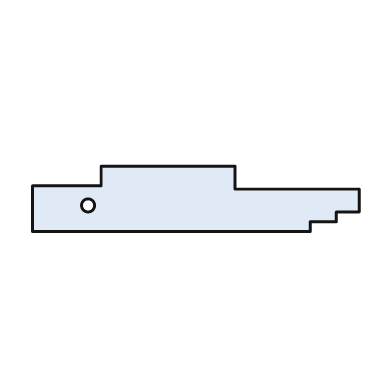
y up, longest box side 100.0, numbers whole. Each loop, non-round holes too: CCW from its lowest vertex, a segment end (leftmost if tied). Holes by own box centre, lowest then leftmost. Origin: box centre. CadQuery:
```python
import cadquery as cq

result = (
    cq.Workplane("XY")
    .moveTo(-50.0, -10.0)
    .lineTo(35.0, -10.0)
    .lineTo(35.0, -7.0)
    .lineTo(43.0, -7.0)
    .lineTo(43.0, -4.0)
    .lineTo(50.0, -4.0)
    .lineTo(50.0, 3.0)
    .lineTo(12.0, 3.0)
    .lineTo(12.0, 10.0)
    .lineTo(-29.0, 10.0)
    .lineTo(-29.0, 4.0)
    .lineTo(-50.0, 4.0)
    .close()
    .moveTo(-33.0, -2.0)
    .circle(2.0)
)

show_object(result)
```